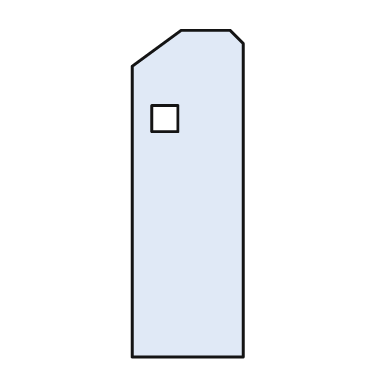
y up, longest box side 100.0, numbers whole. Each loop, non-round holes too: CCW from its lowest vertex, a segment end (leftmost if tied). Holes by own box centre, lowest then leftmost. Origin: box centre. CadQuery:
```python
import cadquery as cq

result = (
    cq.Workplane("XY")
    .moveTo(-17.0, -50.0)
    .lineTo(17.0, -50.0)
    .lineTo(17.0, 46.0)
    .lineTo(13.0, 50.0)
    .lineTo(-2.0, 50.0)
    .lineTo(-17.0, 39.0)
    .close()
    .moveTo(-11.0, 19.0)
    .lineTo(-3.0, 19.0)
    .lineTo(-3.0, 27.0)
    .lineTo(-11.0, 27.0)
    .close()
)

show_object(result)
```